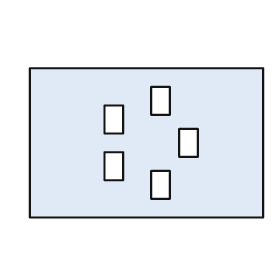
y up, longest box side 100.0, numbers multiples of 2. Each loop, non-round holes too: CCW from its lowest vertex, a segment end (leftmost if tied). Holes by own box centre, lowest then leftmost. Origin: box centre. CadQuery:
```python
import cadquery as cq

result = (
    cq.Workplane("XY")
    .moveTo(-50.0, -32.0)
    .lineTo(50.0, -32.0)
    .lineTo(50.0, 32.0)
    .lineTo(-50.0, 32.0)
    .close()
    .moveTo(2.0, -24.0)
    .lineTo(10.0, -24.0)
    .lineTo(10.0, -12.0)
    .lineTo(2.0, -12.0)
    .close()
    .moveTo(-18.0, -16.0)
    .lineTo(-10.0, -16.0)
    .lineTo(-10.0, -4.0)
    .lineTo(-18.0, -4.0)
    .close()
    .moveTo(14.0, -6.0)
    .lineTo(22.0, -6.0)
    .lineTo(22.0, 6.0)
    .lineTo(14.0, 6.0)
    .close()
    .moveTo(-18.0, 4.0)
    .lineTo(-10.0, 4.0)
    .lineTo(-10.0, 16.0)
    .lineTo(-18.0, 16.0)
    .close()
    .moveTo(2.0, 12.0)
    .lineTo(10.0, 12.0)
    .lineTo(10.0, 24.0)
    .lineTo(2.0, 24.0)
    .close()
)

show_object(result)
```